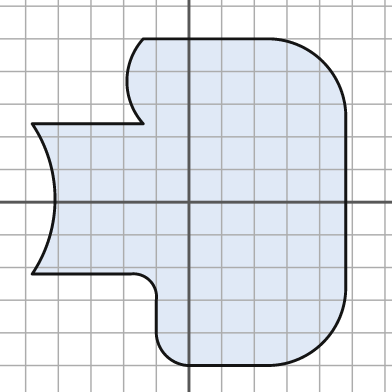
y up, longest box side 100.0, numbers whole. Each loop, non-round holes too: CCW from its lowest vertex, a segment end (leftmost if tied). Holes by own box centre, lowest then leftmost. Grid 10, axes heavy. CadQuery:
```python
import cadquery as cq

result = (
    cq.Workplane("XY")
    .moveTo(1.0, -50.0)
    .lineTo(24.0, -50.0)
    .threePointArc((41.0, -43.0), (48.0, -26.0))
    .lineTo(48.0, 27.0)
    .threePointArc((41.0, 43.0), (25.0, 50.0))
    .lineTo(-14.0, 50.0)
    .threePointArc((-19.0, 37.0), (-14.0, 24.0))
    .lineTo(-48.0, 24.0)
    .threePointArc((-41.0, 1.0), (-48.0, -22.0))
    .lineTo(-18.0, -22.0)
    .threePointArc((-12.0, -24.0), (-10.0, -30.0))
    .lineTo(-10.0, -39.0)
    .threePointArc((-7.0, -47.0), (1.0, -50.0))
    .close()
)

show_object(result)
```